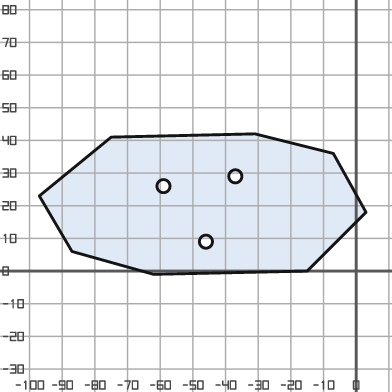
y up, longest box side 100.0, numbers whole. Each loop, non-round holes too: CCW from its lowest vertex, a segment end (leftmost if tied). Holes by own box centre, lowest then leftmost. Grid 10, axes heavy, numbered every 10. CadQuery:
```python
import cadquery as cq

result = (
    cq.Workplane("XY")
    .moveTo(-62.0, -1.0)
    .lineTo(-15.0, 0.0)
    .lineTo(3.0, 18.0)
    .lineTo(-7.0, 36.0)
    .lineTo(-31.0, 42.0)
    .lineTo(-75.0, 41.0)
    .lineTo(-97.0, 23.0)
    .lineTo(-87.0, 6.0)
    .close()
    .moveTo(-46.0, 9.0)
    .circle(2.0)
    .moveTo(-59.0, 26.0)
    .circle(2.0)
    .moveTo(-37.0, 29.0)
    .circle(2.0)
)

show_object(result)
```